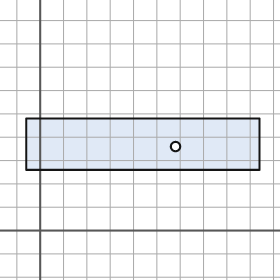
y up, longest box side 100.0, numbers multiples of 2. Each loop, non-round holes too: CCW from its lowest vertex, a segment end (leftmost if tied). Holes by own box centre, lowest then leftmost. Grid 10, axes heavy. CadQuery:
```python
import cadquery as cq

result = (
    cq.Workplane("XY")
    .moveTo(-6.0, 26.0)
    .lineTo(94.0, 26.0)
    .lineTo(94.0, 48.0)
    .lineTo(-6.0, 48.0)
    .close()
    .moveTo(58.0, 36.0)
    .circle(2.0)
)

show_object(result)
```